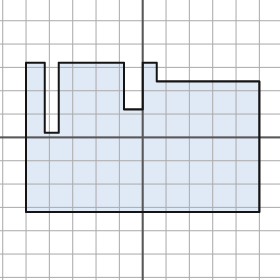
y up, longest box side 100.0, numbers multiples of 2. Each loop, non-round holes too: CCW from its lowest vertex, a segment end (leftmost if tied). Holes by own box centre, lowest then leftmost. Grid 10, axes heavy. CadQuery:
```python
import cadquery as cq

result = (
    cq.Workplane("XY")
    .moveTo(-50.0, -32.0)
    .lineTo(50.0, -32.0)
    .lineTo(50.0, 24.0)
    .lineTo(6.0, 24.0)
    .lineTo(6.0, 32.0)
    .lineTo(0.0, 32.0)
    .lineTo(0.0, 12.0)
    .lineTo(-8.0, 12.0)
    .lineTo(-8.0, 32.0)
    .lineTo(-36.0, 32.0)
    .lineTo(-36.0, 2.0)
    .lineTo(-42.0, 2.0)
    .lineTo(-42.0, 32.0)
    .lineTo(-50.0, 32.0)
    .close()
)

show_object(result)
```